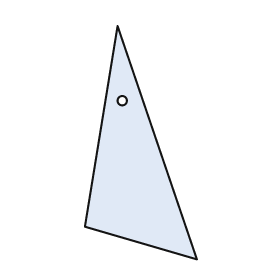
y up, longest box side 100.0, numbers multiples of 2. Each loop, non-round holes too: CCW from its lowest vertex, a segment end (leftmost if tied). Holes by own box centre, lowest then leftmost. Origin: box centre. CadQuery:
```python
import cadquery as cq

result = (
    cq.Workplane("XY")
    .moveTo(24.0, -50.0)
    .lineTo(-10.0, 50.0)
    .lineTo(-24.0, -36.0)
    .close()
    .moveTo(-8.0, 18.0)
    .circle(2.0)
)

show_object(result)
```